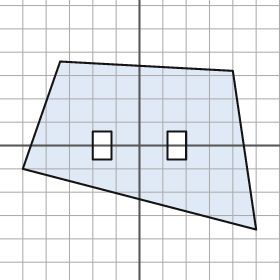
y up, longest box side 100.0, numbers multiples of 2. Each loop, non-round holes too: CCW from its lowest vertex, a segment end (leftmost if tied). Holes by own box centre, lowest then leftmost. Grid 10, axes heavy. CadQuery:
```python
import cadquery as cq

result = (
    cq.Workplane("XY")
    .moveTo(50.0, -36.0)
    .lineTo(40.0, 32.0)
    .lineTo(-34.0, 36.0)
    .lineTo(-50.0, -10.0)
    .close()
    .moveTo(-20.0, -6.0)
    .lineTo(-12.0, -6.0)
    .lineTo(-12.0, 6.0)
    .lineTo(-20.0, 6.0)
    .close()
    .moveTo(12.0, -6.0)
    .lineTo(20.0, -6.0)
    .lineTo(20.0, 6.0)
    .lineTo(12.0, 6.0)
    .close()
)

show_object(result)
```